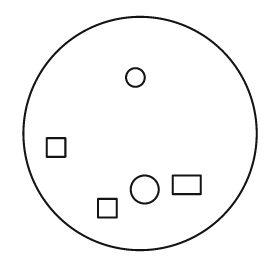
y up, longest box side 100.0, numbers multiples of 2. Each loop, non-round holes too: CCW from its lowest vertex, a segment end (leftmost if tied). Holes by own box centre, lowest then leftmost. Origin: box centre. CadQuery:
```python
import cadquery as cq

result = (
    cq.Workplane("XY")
    .moveTo(0.0, 0.0)
    .circle(50.0)
    .moveTo(-18.0, -36.0)
    .lineTo(-10.0, -36.0)
    .lineTo(-10.0, -28.0)
    .lineTo(-18.0, -28.0)
    .close()
    .moveTo(2.0, -24.0)
    .circle(6.0)
    .moveTo(14.0, -26.0)
    .lineTo(26.0, -26.0)
    .lineTo(26.0, -18.0)
    .lineTo(14.0, -18.0)
    .close()
    .moveTo(-40.0, -10.0)
    .lineTo(-32.0, -10.0)
    .lineTo(-32.0, -2.0)
    .lineTo(-40.0, -2.0)
    .close()
    .moveTo(-2.0, 24.0)
    .circle(4.0)
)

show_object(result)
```